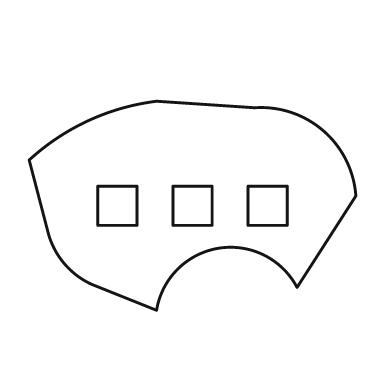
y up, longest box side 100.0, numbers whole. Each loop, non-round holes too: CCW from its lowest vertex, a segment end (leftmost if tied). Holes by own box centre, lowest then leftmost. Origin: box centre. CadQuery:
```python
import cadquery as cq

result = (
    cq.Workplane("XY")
    .moveTo(-11.0, -32.0)
    .threePointArc((8.0, -13.0), (32.0, -25.0))
    .lineTo(50.0, 3.0)
    .threePointArc((40.0, 23.0), (19.0, 30.0))
    .lineTo(-11.0, 32.0)
    .threePointArc((-32.0, 26.0), (-50.0, 14.0))
    .lineTo(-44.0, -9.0)
    .threePointArc((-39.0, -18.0), (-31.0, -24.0))
    .close()
    .moveTo(-29.0, -6.0)
    .lineTo(-17.0, -6.0)
    .lineTo(-17.0, 6.0)
    .lineTo(-29.0, 6.0)
    .close()
    .moveTo(-6.0, -6.0)
    .lineTo(6.0, -6.0)
    .lineTo(6.0, 6.0)
    .lineTo(-6.0, 6.0)
    .close()
    .moveTo(17.0, -6.0)
    .lineTo(29.0, -6.0)
    .lineTo(29.0, 6.0)
    .lineTo(17.0, 6.0)
    .close()
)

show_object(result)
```